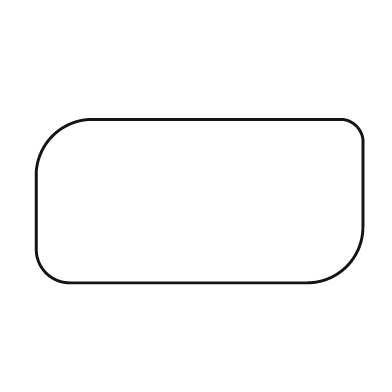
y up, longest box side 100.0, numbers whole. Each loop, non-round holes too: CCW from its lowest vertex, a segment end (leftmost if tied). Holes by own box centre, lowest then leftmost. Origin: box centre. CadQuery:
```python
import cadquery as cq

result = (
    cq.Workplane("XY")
    .moveTo(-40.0, -25.0)
    .lineTo(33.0, -25.0)
    .threePointArc((45.0, -20.0), (50.0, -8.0))
    .lineTo(50.0, 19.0)
    .threePointArc((48.0, 23.0), (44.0, 25.0))
    .lineTo(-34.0, 25.0)
    .threePointArc((-45.0, 20.0), (-50.0, 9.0))
    .lineTo(-50.0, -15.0)
    .threePointArc((-47.0, -22.0), (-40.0, -25.0))
    .close()
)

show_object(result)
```